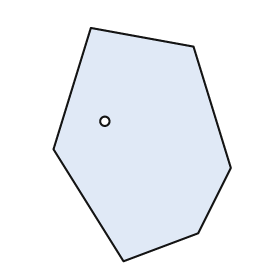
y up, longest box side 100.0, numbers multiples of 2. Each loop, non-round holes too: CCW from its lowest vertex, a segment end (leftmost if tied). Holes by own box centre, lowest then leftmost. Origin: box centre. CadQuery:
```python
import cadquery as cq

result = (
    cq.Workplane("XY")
    .moveTo(-8.0, -50.0)
    .lineTo(24.0, -38.0)
    .lineTo(38.0, -10.0)
    .lineTo(22.0, 42.0)
    .lineTo(-22.0, 50.0)
    .lineTo(-38.0, -2.0)
    .close()
    .moveTo(-16.0, 10.0)
    .circle(2.0)
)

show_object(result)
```